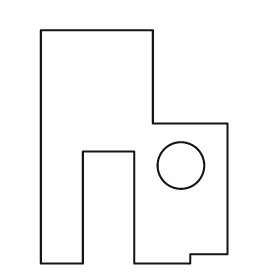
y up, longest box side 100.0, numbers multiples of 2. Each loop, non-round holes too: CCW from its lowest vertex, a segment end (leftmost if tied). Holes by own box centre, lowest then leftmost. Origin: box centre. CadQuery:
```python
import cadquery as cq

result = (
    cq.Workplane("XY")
    .moveTo(-40.0, -50.0)
    .lineTo(-22.0, -50.0)
    .lineTo(-22.0, -2.0)
    .lineTo(0.0, -2.0)
    .lineTo(0.0, -50.0)
    .lineTo(24.0, -50.0)
    .lineTo(24.0, -46.0)
    .lineTo(40.0, -46.0)
    .lineTo(40.0, 10.0)
    .lineTo(8.0, 10.0)
    .lineTo(8.0, 50.0)
    .lineTo(-40.0, 50.0)
    .close()
    .moveTo(20.0, -8.0)
    .circle(10.0)
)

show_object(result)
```